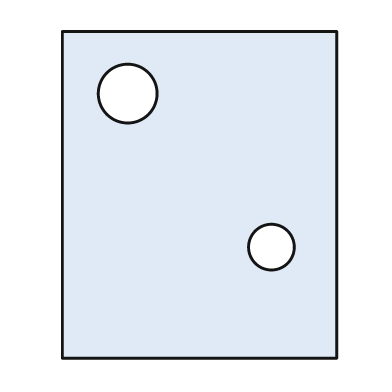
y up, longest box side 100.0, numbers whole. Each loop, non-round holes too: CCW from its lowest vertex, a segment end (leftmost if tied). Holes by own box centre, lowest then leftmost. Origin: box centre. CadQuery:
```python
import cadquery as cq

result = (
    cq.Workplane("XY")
    .moveTo(-42.0, -50.0)
    .lineTo(42.0, -50.0)
    .lineTo(42.0, 50.0)
    .lineTo(-42.0, 50.0)
    .close()
    .moveTo(22.0, -16.0)
    .circle(7.0)
    .moveTo(-22.0, 31.0)
    .circle(9.0)
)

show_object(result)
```